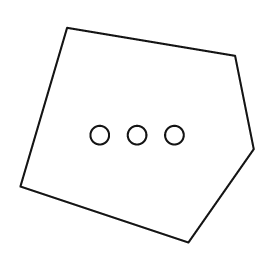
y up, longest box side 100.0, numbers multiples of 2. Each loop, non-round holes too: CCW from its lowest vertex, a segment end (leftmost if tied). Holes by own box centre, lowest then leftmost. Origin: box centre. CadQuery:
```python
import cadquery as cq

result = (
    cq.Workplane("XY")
    .moveTo(22.0, -46.0)
    .lineTo(50.0, -6.0)
    .lineTo(42.0, 34.0)
    .lineTo(-30.0, 46.0)
    .lineTo(-50.0, -22.0)
    .close()
    .moveTo(-16.0, 0.0)
    .circle(4.0)
    .moveTo(0.0, 0.0)
    .circle(4.0)
    .moveTo(16.0, 0.0)
    .circle(4.0)
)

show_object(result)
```